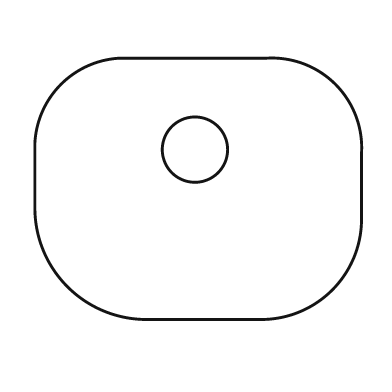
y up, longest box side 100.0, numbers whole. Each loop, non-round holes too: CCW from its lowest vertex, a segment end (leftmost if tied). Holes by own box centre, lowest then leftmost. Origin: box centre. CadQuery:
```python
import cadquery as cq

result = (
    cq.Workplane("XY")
    .moveTo(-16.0, -40.0)
    .lineTo(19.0, -40.0)
    .threePointArc((41.0, -31.0), (50.0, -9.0))
    .lineTo(50.0, 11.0)
    .threePointArc((42.0, 32.0), (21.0, 40.0))
    .lineTo(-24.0, 40.0)
    .threePointArc((-42.0, 32.0), (-50.0, 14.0))
    .lineTo(-50.0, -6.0)
    .threePointArc((-40.0, -30.0), (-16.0, -40.0))
    .close()
    .moveTo(-1.0, 12.0)
    .circle(10.0)
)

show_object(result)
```